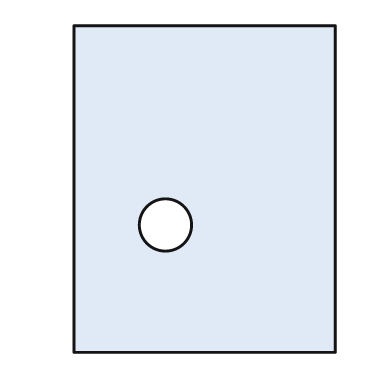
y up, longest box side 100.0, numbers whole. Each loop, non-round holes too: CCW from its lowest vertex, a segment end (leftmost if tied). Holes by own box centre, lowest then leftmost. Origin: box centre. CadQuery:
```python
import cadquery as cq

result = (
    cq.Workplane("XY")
    .moveTo(-40.0, -50.0)
    .lineTo(40.0, -50.0)
    .lineTo(40.0, 50.0)
    .lineTo(-40.0, 50.0)
    .close()
    .moveTo(-12.0, -11.0)
    .circle(8.0)
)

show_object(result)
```